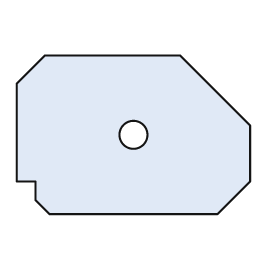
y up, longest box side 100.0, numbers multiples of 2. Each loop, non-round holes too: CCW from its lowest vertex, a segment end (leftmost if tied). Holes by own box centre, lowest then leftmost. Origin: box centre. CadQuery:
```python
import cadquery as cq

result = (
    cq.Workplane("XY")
    .moveTo(-36.0, -34.0)
    .lineTo(36.0, -34.0)
    .lineTo(50.0, -20.0)
    .lineTo(50.0, 4.0)
    .lineTo(20.0, 34.0)
    .lineTo(-38.0, 34.0)
    .lineTo(-50.0, 22.0)
    .lineTo(-50.0, -20.0)
    .lineTo(-42.0, -20.0)
    .lineTo(-42.0, -28.0)
    .close()
    .moveTo(0.0, 0.0)
    .circle(6.0)
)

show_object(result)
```